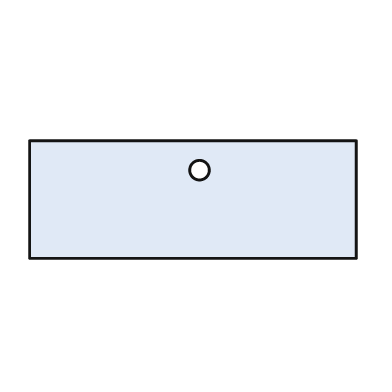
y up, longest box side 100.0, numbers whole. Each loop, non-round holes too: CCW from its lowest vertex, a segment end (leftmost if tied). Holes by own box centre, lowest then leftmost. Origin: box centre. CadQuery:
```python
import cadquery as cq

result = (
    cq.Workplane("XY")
    .moveTo(-50.0, -18.0)
    .lineTo(50.0, -18.0)
    .lineTo(50.0, 18.0)
    .lineTo(-50.0, 18.0)
    .close()
    .moveTo(2.0, 9.0)
    .circle(3.0)
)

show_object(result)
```